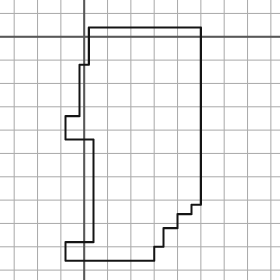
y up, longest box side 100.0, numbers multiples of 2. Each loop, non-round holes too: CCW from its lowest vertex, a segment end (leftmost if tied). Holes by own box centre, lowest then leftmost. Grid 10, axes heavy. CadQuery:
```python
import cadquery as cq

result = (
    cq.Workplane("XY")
    .moveTo(-8.0, -96.0)
    .lineTo(30.0, -96.0)
    .lineTo(30.0, -90.0)
    .lineTo(34.0, -90.0)
    .lineTo(34.0, -82.0)
    .lineTo(40.0, -82.0)
    .lineTo(40.0, -76.0)
    .lineTo(46.0, -76.0)
    .lineTo(46.0, -72.0)
    .lineTo(50.0, -72.0)
    .lineTo(50.0, 4.0)
    .lineTo(2.0, 4.0)
    .lineTo(2.0, -12.0)
    .lineTo(-2.0, -12.0)
    .lineTo(-2.0, -34.0)
    .lineTo(-8.0, -34.0)
    .lineTo(-8.0, -44.0)
    .lineTo(4.0, -44.0)
    .lineTo(4.0, -88.0)
    .lineTo(-8.0, -88.0)
    .close()
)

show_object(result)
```